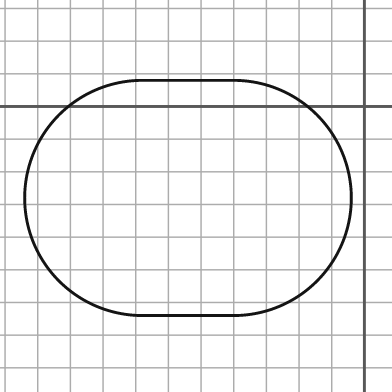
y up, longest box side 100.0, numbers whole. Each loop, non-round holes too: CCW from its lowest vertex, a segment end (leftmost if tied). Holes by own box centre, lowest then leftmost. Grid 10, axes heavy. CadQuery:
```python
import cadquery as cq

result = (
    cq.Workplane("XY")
    .moveTo(-68.0, -64.0)
    .lineTo(-40.0, -64.0)
    .threePointArc((-4.0, -28.0), (-40.0, 8.0))
    .lineTo(-68.0, 8.0)
    .threePointArc((-104.0, -28.0), (-68.0, -64.0))
    .close()
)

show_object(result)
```